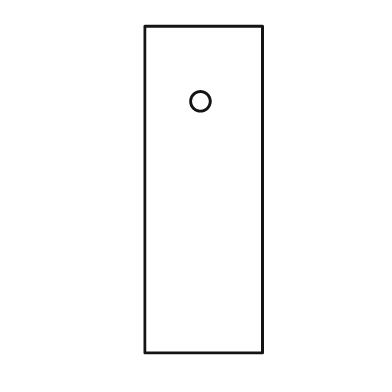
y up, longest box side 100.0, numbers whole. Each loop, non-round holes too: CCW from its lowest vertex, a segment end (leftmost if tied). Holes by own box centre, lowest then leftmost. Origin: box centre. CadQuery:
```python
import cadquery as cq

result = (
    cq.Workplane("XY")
    .moveTo(-18.0, -50.0)
    .lineTo(18.0, -50.0)
    .lineTo(18.0, 50.0)
    .lineTo(-18.0, 50.0)
    .close()
    .moveTo(-1.0, 27.0)
    .circle(3.0)
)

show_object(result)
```